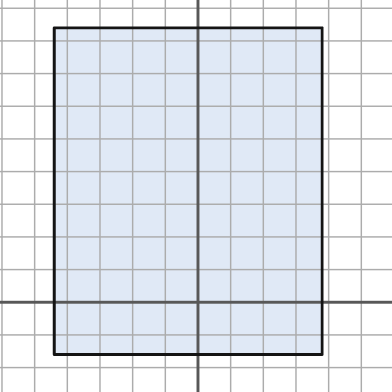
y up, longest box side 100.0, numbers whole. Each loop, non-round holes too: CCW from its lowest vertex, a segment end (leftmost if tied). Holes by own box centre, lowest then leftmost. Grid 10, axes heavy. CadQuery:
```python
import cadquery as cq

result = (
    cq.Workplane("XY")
    .moveTo(-44.0, -16.0)
    .lineTo(38.0, -16.0)
    .lineTo(38.0, 84.0)
    .lineTo(-44.0, 84.0)
    .close()
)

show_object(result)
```